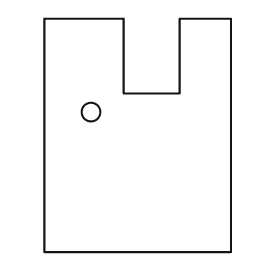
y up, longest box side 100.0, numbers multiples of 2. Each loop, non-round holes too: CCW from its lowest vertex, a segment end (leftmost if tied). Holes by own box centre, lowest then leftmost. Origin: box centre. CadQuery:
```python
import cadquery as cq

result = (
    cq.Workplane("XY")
    .moveTo(-40.0, -50.0)
    .lineTo(40.0, -50.0)
    .lineTo(40.0, 50.0)
    .lineTo(18.0, 50.0)
    .lineTo(18.0, 18.0)
    .lineTo(-6.0, 18.0)
    .lineTo(-6.0, 50.0)
    .lineTo(-40.0, 50.0)
    .close()
    .moveTo(-20.0, 10.0)
    .circle(4.0)
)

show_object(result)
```